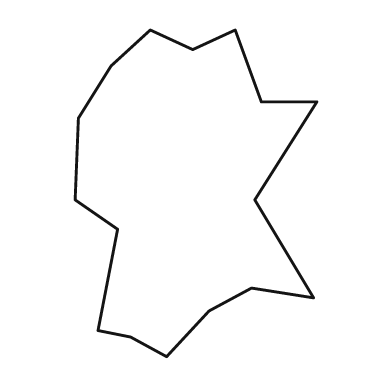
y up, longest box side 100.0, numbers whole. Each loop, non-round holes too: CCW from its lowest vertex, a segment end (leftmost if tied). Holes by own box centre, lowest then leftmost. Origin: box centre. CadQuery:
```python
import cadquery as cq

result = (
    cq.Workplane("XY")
    .moveTo(-9.0, -50.0)
    .lineTo(4.0, -36.0)
    .lineTo(17.0, -29.0)
    .lineTo(36.0, -32.0)
    .lineTo(18.0, -2.0)
    .lineTo(37.0, 28.0)
    .lineTo(20.0, 28.0)
    .lineTo(12.0, 50.0)
    .lineTo(-1.0, 44.0)
    .lineTo(-14.0, 50.0)
    .lineTo(-26.0, 39.0)
    .lineTo(-36.0, 23.0)
    .lineTo(-37.0, -2.0)
    .lineTo(-24.0, -11.0)
    .lineTo(-30.0, -42.0)
    .lineTo(-20.0, -44.0)
    .close()
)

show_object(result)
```